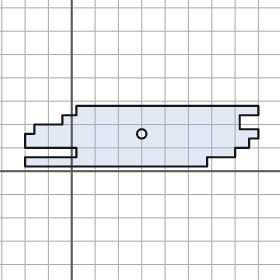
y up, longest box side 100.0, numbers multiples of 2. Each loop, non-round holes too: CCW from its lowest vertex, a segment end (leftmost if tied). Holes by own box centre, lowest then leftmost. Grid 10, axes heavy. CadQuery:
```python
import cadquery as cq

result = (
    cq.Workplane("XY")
    .moveTo(-20.0, 2.0)
    .lineTo(58.0, 2.0)
    .lineTo(58.0, 6.0)
    .lineTo(70.0, 6.0)
    .lineTo(70.0, 10.0)
    .lineTo(76.0, 10.0)
    .lineTo(76.0, 14.0)
    .lineTo(80.0, 14.0)
    .lineTo(80.0, 18.0)
    .lineTo(72.0, 18.0)
    .lineTo(72.0, 24.0)
    .lineTo(80.0, 24.0)
    .lineTo(80.0, 28.0)
    .lineTo(2.0, 28.0)
    .lineTo(2.0, 24.0)
    .lineTo(-4.0, 24.0)
    .lineTo(-4.0, 20.0)
    .lineTo(-16.0, 20.0)
    .lineTo(-16.0, 16.0)
    .lineTo(-20.0, 16.0)
    .lineTo(-20.0, 10.0)
    .lineTo(2.0, 10.0)
    .lineTo(2.0, 6.0)
    .lineTo(-20.0, 6.0)
    .close()
    .moveTo(30.0, 16.0)
    .circle(2.0)
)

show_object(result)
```